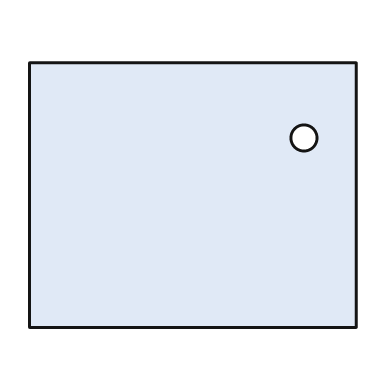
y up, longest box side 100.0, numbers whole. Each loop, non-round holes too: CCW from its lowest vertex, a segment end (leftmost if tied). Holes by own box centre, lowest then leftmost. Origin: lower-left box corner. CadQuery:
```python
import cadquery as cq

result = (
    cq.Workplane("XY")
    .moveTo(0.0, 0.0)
    .lineTo(100.0, 0.0)
    .lineTo(100.0, 81.0)
    .lineTo(0.0, 81.0)
    .close()
    .moveTo(84.0, 58.0)
    .circle(4.0)
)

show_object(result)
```